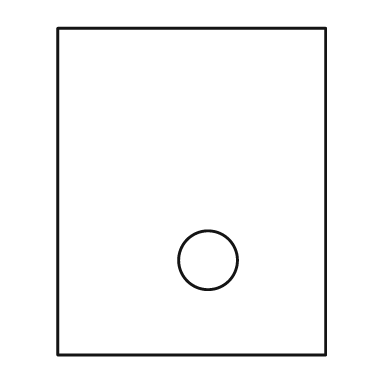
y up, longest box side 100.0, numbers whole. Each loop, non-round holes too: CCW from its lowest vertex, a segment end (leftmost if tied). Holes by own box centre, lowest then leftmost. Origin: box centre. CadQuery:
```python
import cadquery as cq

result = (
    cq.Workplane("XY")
    .moveTo(-41.0, -50.0)
    .lineTo(41.0, -50.0)
    .lineTo(41.0, 50.0)
    .lineTo(-41.0, 50.0)
    .close()
    .moveTo(5.0, -21.0)
    .circle(9.0)
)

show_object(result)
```